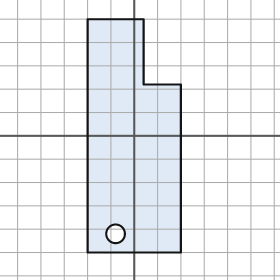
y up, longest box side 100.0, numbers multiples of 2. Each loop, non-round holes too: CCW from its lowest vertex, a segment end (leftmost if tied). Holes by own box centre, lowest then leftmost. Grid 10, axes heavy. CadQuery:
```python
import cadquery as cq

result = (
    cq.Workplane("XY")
    .moveTo(-20.0, -50.0)
    .lineTo(20.0, -50.0)
    .lineTo(20.0, 22.0)
    .lineTo(4.0, 22.0)
    .lineTo(4.0, 50.0)
    .lineTo(-20.0, 50.0)
    .close()
    .moveTo(-8.0, -42.0)
    .circle(4.0)
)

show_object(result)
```